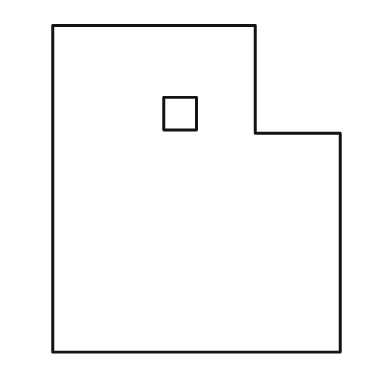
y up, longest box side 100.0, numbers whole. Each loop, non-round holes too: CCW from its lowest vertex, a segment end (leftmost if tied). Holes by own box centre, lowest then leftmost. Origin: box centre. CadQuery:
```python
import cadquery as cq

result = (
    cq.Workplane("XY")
    .moveTo(-44.0, -50.0)
    .lineTo(44.0, -50.0)
    .lineTo(44.0, 17.0)
    .lineTo(18.0, 17.0)
    .lineTo(18.0, 50.0)
    .lineTo(-44.0, 50.0)
    .close()
    .moveTo(-10.0, 18.0)
    .lineTo(0.0, 18.0)
    .lineTo(0.0, 28.0)
    .lineTo(-10.0, 28.0)
    .close()
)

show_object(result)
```